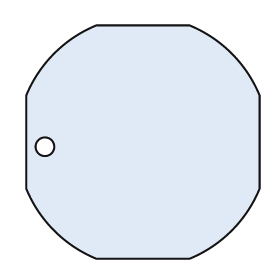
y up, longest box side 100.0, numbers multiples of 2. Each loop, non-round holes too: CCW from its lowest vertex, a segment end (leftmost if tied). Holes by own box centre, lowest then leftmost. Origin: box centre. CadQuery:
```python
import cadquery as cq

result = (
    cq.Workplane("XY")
    .moveTo(-20.0, -50.0)
    .lineTo(20.0, -50.0)
    .threePointArc((38.0, -38.0), (50.0, -20.0))
    .lineTo(50.0, 20.0)
    .threePointArc((38.0, 38.0), (20.0, 50.0))
    .lineTo(-20.0, 50.0)
    .threePointArc((-38.0, 38.0), (-50.0, 20.0))
    .lineTo(-50.0, -20.0)
    .threePointArc((-38.0, -38.0), (-20.0, -50.0))
    .close()
    .moveTo(-42.0, -2.0)
    .circle(4.0)
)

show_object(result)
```